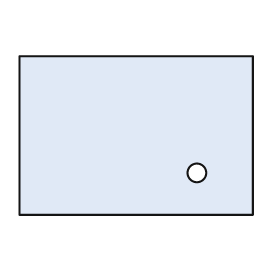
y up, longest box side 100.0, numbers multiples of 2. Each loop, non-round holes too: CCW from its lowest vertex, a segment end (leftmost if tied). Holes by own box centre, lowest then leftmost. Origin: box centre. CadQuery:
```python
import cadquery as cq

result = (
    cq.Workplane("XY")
    .moveTo(-50.0, -34.0)
    .lineTo(50.0, -34.0)
    .lineTo(50.0, 34.0)
    .lineTo(-50.0, 34.0)
    .close()
    .moveTo(26.0, -16.0)
    .circle(4.0)
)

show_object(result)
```